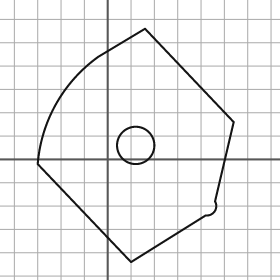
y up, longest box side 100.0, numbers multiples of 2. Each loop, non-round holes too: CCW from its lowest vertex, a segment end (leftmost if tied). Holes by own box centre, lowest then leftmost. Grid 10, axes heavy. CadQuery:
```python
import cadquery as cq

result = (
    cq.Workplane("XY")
    .moveTo(10.0, -44.0)
    .lineTo(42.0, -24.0)
    .threePointArc((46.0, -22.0), (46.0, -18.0))
    .lineTo(54.0, 16.0)
    .lineTo(16.0, 56.0)
    .lineTo(-4.0, 44.0)
    .threePointArc((-22.0, 24.0), (-30.0, -2.0))
    .close()
    .moveTo(12.0, 6.0)
    .circle(8.0)
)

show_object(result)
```